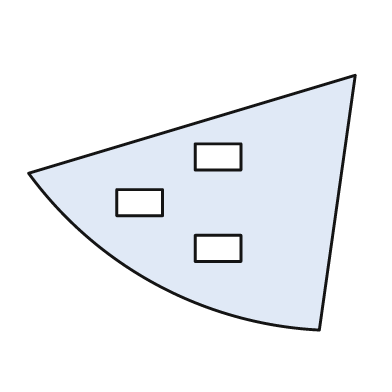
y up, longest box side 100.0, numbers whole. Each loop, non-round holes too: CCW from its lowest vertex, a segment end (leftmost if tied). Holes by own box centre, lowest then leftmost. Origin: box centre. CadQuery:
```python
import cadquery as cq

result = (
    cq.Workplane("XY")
    .moveTo(39.0, -39.0)
    .lineTo(50.0, 39.0)
    .lineTo(-50.0, 9.0)
    .threePointArc((-11.0, -25.0), (39.0, -39.0))
    .close()
    .moveTo(1.0, -18.0)
    .lineTo(15.0, -18.0)
    .lineTo(15.0, -10.0)
    .lineTo(1.0, -10.0)
    .close()
    .moveTo(-23.0, -4.0)
    .lineTo(-9.0, -4.0)
    .lineTo(-9.0, 4.0)
    .lineTo(-23.0, 4.0)
    .close()
    .moveTo(1.0, 10.0)
    .lineTo(15.0, 10.0)
    .lineTo(15.0, 18.0)
    .lineTo(1.0, 18.0)
    .close()
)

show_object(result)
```